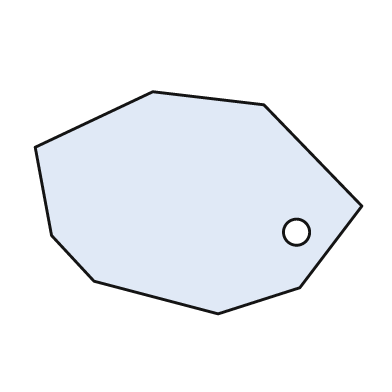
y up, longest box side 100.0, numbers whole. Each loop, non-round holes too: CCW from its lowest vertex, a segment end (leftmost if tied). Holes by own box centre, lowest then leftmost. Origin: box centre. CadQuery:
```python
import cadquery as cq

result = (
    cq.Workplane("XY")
    .moveTo(6.0, -34.0)
    .lineTo(31.0, -26.0)
    .lineTo(50.0, -1.0)
    .lineTo(20.0, 30.0)
    .lineTo(-14.0, 34.0)
    .lineTo(-50.0, 17.0)
    .lineTo(-45.0, -10.0)
    .lineTo(-32.0, -24.0)
    .close()
    .moveTo(30.0, -9.0)
    .circle(4.0)
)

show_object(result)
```